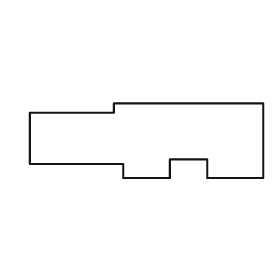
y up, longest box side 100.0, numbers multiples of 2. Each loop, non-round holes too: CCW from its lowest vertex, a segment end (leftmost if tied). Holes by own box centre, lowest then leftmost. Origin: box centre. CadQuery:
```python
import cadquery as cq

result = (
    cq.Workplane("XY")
    .moveTo(-10.0, -16.0)
    .lineTo(10.0, -16.0)
    .lineTo(10.0, -8.0)
    .lineTo(26.0, -8.0)
    .lineTo(26.0, -16.0)
    .lineTo(50.0, -16.0)
    .lineTo(50.0, 16.0)
    .lineTo(-14.0, 16.0)
    .lineTo(-14.0, 12.0)
    .lineTo(-50.0, 12.0)
    .lineTo(-50.0, -10.0)
    .lineTo(-10.0, -10.0)
    .close()
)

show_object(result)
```